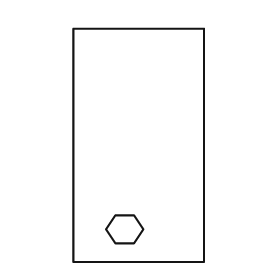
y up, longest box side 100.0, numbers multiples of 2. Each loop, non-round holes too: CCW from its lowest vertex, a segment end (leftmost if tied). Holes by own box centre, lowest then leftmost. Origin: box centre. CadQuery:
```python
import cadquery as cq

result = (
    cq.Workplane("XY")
    .moveTo(-28.0, -50.0)
    .lineTo(28.0, -50.0)
    .lineTo(28.0, 50.0)
    .lineTo(-28.0, 50.0)
    .close()
    .moveTo(-10.0, -42.0)
    .lineTo(-2.0, -42.0)
    .lineTo(2.0, -36.0)
    .lineTo(-2.0, -30.0)
    .lineTo(-10.0, -30.0)
    .lineTo(-14.0, -36.0)
    .close()
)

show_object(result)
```